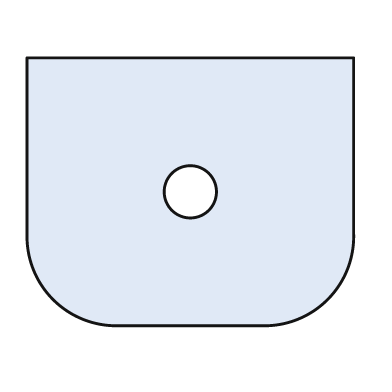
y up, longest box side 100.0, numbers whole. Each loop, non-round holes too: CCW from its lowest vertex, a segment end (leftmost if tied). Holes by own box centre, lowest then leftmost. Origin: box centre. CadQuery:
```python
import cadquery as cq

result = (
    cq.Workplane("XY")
    .moveTo(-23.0, -41.0)
    .lineTo(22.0, -41.0)
    .threePointArc((42.0, -33.0), (50.0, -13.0))
    .lineTo(50.0, 41.0)
    .lineTo(-50.0, 41.0)
    .lineTo(-50.0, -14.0)
    .threePointArc((-42.0, -33.0), (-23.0, -41.0))
    .close()
    .moveTo(0.0, 0.0)
    .circle(8.0)
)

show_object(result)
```